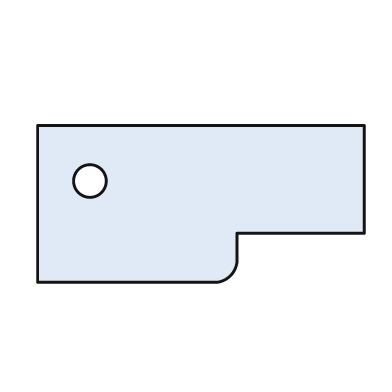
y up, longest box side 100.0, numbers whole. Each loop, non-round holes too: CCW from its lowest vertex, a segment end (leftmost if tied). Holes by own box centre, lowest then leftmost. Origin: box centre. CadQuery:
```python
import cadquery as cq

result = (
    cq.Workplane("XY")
    .moveTo(-50.0, -24.0)
    .lineTo(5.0, -24.0)
    .threePointArc((9.0, -22.0), (11.0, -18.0))
    .lineTo(11.0, -9.0)
    .lineTo(50.0, -9.0)
    .lineTo(50.0, 24.0)
    .lineTo(-50.0, 24.0)
    .close()
    .moveTo(-34.0, 7.0)
    .circle(5.0)
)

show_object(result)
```